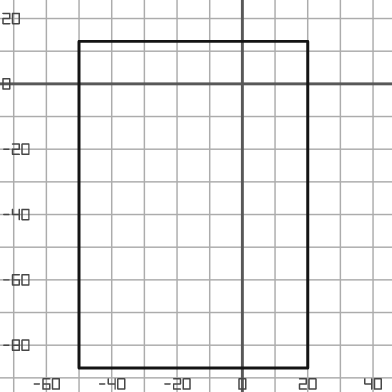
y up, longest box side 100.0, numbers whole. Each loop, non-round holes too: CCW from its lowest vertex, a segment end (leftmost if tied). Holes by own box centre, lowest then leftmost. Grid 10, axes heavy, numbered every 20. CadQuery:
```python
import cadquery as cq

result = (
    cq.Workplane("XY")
    .moveTo(-50.0, -87.0)
    .lineTo(20.0, -87.0)
    .lineTo(20.0, 13.0)
    .lineTo(-50.0, 13.0)
    .close()
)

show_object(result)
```